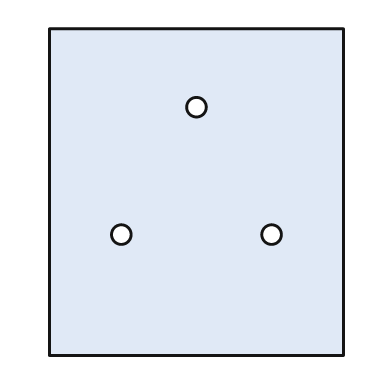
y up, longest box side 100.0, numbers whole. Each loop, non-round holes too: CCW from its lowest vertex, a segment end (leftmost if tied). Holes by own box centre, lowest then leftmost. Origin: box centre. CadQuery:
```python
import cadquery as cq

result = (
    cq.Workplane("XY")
    .moveTo(-45.0, -50.0)
    .lineTo(45.0, -50.0)
    .lineTo(45.0, 50.0)
    .lineTo(-45.0, 50.0)
    .close()
    .moveTo(-23.0, -13.0)
    .circle(3.0)
    .moveTo(23.0, -13.0)
    .circle(3.0)
    .moveTo(0.0, 26.0)
    .circle(3.0)
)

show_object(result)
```